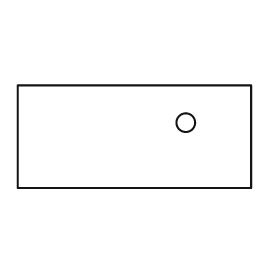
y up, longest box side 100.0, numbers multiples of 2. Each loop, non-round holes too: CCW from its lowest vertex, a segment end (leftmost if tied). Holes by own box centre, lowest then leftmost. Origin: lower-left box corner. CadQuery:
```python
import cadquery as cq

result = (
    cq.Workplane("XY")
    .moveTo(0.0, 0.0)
    .lineTo(100.0, 0.0)
    .lineTo(100.0, 44.0)
    .lineTo(0.0, 44.0)
    .close()
    .moveTo(72.0, 28.0)
    .circle(4.0)
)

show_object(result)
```